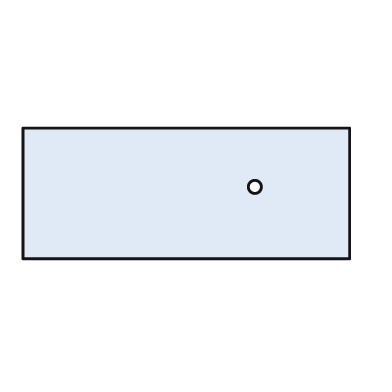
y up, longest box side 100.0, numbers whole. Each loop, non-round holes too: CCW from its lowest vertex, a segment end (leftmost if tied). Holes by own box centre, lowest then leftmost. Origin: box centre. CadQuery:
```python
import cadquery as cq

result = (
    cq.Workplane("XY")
    .moveTo(-50.0, -20.0)
    .lineTo(50.0, -20.0)
    .lineTo(50.0, 20.0)
    .lineTo(-50.0, 20.0)
    .close()
    .moveTo(21.0, 2.0)
    .circle(2.0)
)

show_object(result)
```